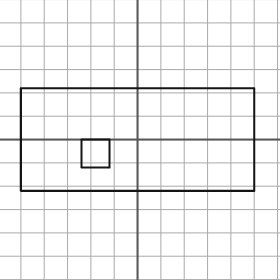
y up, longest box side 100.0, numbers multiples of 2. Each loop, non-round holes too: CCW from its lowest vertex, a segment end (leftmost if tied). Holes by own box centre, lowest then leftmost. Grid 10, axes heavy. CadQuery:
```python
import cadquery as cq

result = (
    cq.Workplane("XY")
    .moveTo(-50.0, -22.0)
    .lineTo(50.0, -22.0)
    .lineTo(50.0, 22.0)
    .lineTo(-50.0, 22.0)
    .close()
    .moveTo(-24.0, -12.0)
    .lineTo(-12.0, -12.0)
    .lineTo(-12.0, 0.0)
    .lineTo(-24.0, 0.0)
    .close()
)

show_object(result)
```